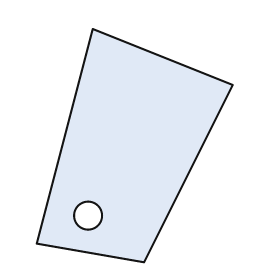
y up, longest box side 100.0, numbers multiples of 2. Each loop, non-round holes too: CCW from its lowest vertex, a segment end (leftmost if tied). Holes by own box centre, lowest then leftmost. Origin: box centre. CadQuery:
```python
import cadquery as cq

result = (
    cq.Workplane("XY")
    .moveTo(4.0, -50.0)
    .lineTo(42.0, 26.0)
    .lineTo(-18.0, 50.0)
    .lineTo(-42.0, -42.0)
    .close()
    .moveTo(-20.0, -30.0)
    .circle(6.0)
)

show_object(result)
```